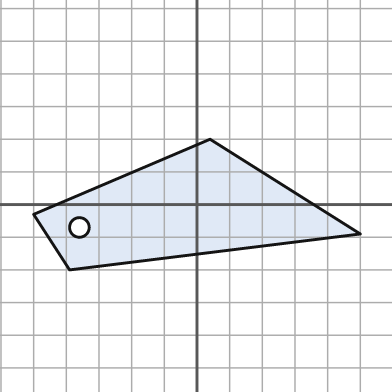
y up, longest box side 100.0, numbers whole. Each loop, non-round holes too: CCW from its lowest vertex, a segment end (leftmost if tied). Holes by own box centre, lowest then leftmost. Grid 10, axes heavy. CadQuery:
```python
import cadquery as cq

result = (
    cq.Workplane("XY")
    .moveTo(-39.0, -20.0)
    .lineTo(50.0, -9.0)
    .lineTo(4.0, 20.0)
    .lineTo(-50.0, -3.0)
    .close()
    .moveTo(-36.0, -7.0)
    .circle(3.0)
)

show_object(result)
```